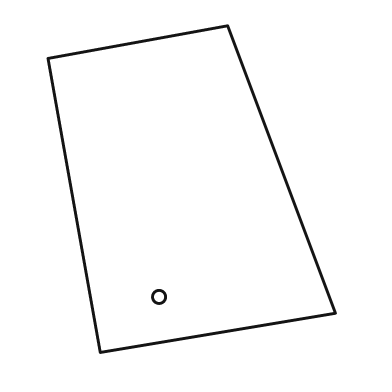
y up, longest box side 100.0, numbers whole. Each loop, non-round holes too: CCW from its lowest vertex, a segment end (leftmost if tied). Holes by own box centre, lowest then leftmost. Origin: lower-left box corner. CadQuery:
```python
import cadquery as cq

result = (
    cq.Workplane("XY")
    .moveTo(16.0, 0.0)
    .lineTo(88.0, 12.0)
    .lineTo(55.0, 100.0)
    .lineTo(0.0, 90.0)
    .close()
    .moveTo(34.0, 17.0)
    .circle(2.0)
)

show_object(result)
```